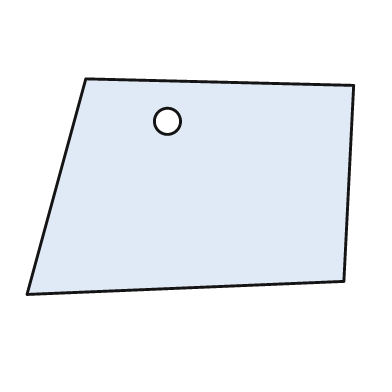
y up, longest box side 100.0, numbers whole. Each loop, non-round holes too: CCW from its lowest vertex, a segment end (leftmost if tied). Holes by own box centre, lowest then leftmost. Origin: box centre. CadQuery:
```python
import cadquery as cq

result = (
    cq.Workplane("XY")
    .moveTo(-50.0, -33.0)
    .lineTo(47.0, -29.0)
    .lineTo(50.0, 31.0)
    .lineTo(-32.0, 33.0)
    .close()
    .moveTo(-7.0, 20.0)
    .circle(4.0)
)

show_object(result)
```